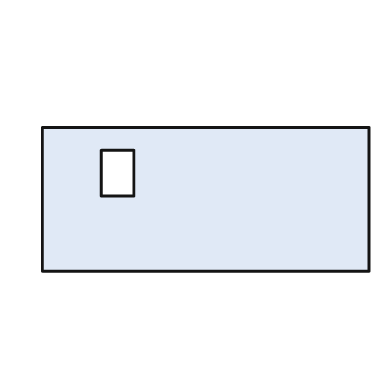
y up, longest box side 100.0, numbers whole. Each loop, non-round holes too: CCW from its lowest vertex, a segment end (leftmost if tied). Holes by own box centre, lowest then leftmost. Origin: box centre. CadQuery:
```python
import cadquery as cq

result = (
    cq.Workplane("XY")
    .moveTo(-50.0, -22.0)
    .lineTo(50.0, -22.0)
    .lineTo(50.0, 22.0)
    .lineTo(-50.0, 22.0)
    .close()
    .moveTo(-32.0, 1.0)
    .lineTo(-22.0, 1.0)
    .lineTo(-22.0, 15.0)
    .lineTo(-32.0, 15.0)
    .close()
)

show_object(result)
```